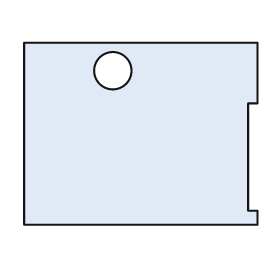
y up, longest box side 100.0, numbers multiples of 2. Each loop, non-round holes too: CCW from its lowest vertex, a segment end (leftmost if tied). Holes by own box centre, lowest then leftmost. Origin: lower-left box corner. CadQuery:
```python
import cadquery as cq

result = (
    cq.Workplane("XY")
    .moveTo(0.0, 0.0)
    .lineTo(100.0, 0.0)
    .lineTo(100.0, 6.0)
    .lineTo(96.0, 6.0)
    .lineTo(96.0, 52.0)
    .lineTo(100.0, 52.0)
    .lineTo(100.0, 78.0)
    .lineTo(0.0, 78.0)
    .close()
    .moveTo(38.0, 66.0)
    .circle(8.0)
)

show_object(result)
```